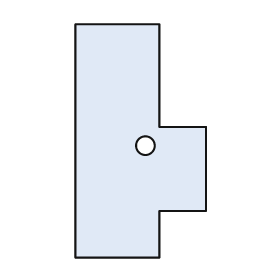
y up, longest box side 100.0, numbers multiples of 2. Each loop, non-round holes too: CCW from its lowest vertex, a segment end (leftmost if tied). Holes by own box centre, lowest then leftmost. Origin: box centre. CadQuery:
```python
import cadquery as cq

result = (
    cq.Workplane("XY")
    .moveTo(-28.0, -50.0)
    .lineTo(8.0, -50.0)
    .lineTo(8.0, -30.0)
    .lineTo(28.0, -30.0)
    .lineTo(28.0, 6.0)
    .lineTo(8.0, 6.0)
    .lineTo(8.0, 50.0)
    .lineTo(-28.0, 50.0)
    .close()
    .moveTo(2.0, -2.0)
    .circle(4.0)
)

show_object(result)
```